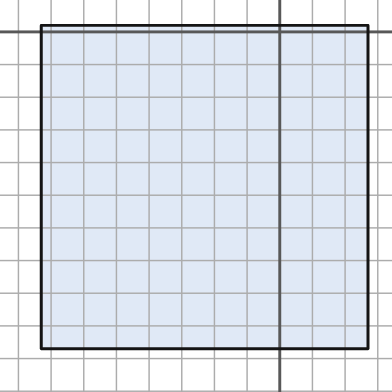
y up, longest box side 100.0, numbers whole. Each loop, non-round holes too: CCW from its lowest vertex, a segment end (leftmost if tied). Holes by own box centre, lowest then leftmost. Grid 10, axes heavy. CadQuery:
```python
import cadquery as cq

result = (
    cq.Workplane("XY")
    .moveTo(-73.0, -97.0)
    .lineTo(27.0, -97.0)
    .lineTo(27.0, 2.0)
    .lineTo(-73.0, 2.0)
    .close()
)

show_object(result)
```